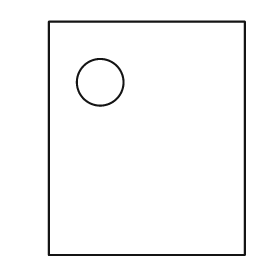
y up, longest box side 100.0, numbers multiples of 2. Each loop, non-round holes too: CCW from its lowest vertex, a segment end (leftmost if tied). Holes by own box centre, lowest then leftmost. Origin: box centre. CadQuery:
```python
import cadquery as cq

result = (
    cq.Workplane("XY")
    .moveTo(-42.0, -50.0)
    .lineTo(42.0, -50.0)
    .lineTo(42.0, 50.0)
    .lineTo(-42.0, 50.0)
    .close()
    .moveTo(-20.0, 24.0)
    .circle(10.0)
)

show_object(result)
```